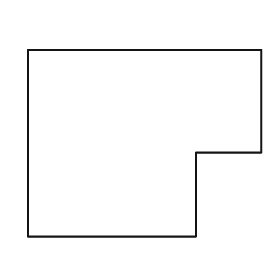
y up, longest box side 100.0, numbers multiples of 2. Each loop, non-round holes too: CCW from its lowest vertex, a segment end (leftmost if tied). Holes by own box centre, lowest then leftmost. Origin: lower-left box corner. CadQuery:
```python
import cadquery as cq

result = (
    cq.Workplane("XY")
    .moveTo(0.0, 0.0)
    .lineTo(72.0, 0.0)
    .lineTo(72.0, 36.0)
    .lineTo(100.0, 36.0)
    .lineTo(100.0, 80.0)
    .lineTo(0.0, 80.0)
    .close()
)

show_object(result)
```